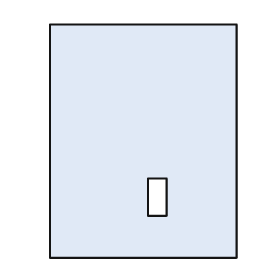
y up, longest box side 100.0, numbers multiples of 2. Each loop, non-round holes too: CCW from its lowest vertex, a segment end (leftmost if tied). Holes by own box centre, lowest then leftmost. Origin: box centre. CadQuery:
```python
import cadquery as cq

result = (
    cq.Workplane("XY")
    .moveTo(-40.0, -50.0)
    .lineTo(40.0, -50.0)
    .lineTo(40.0, 50.0)
    .lineTo(-40.0, 50.0)
    .close()
    .moveTo(2.0, -32.0)
    .lineTo(10.0, -32.0)
    .lineTo(10.0, -16.0)
    .lineTo(2.0, -16.0)
    .close()
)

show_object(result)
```